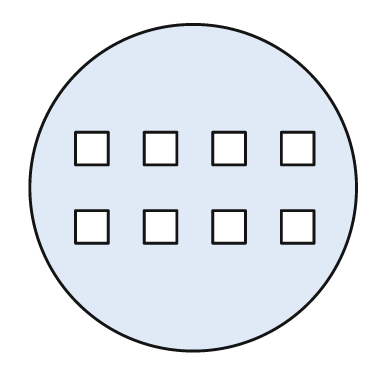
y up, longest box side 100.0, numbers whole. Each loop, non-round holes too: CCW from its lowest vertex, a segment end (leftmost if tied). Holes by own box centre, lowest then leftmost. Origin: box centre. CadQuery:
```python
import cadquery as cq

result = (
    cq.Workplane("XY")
    .moveTo(0.0, 0.0)
    .circle(50.0)
    .moveTo(-36.0, -17.0)
    .lineTo(-26.0, -17.0)
    .lineTo(-26.0, -7.0)
    .lineTo(-36.0, -7.0)
    .close()
    .moveTo(-15.0, -17.0)
    .lineTo(-5.0, -17.0)
    .lineTo(-5.0, -7.0)
    .lineTo(-15.0, -7.0)
    .close()
    .moveTo(6.0, -17.0)
    .lineTo(16.0, -17.0)
    .lineTo(16.0, -7.0)
    .lineTo(6.0, -7.0)
    .close()
    .moveTo(27.0, -17.0)
    .lineTo(37.0, -17.0)
    .lineTo(37.0, -7.0)
    .lineTo(27.0, -7.0)
    .close()
    .moveTo(-36.0, 7.0)
    .lineTo(-26.0, 7.0)
    .lineTo(-26.0, 17.0)
    .lineTo(-36.0, 17.0)
    .close()
    .moveTo(-15.0, 7.0)
    .lineTo(-5.0, 7.0)
    .lineTo(-5.0, 17.0)
    .lineTo(-15.0, 17.0)
    .close()
    .moveTo(6.0, 7.0)
    .lineTo(16.0, 7.0)
    .lineTo(16.0, 17.0)
    .lineTo(6.0, 17.0)
    .close()
    .moveTo(27.0, 7.0)
    .lineTo(37.0, 7.0)
    .lineTo(37.0, 17.0)
    .lineTo(27.0, 17.0)
    .close()
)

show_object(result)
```